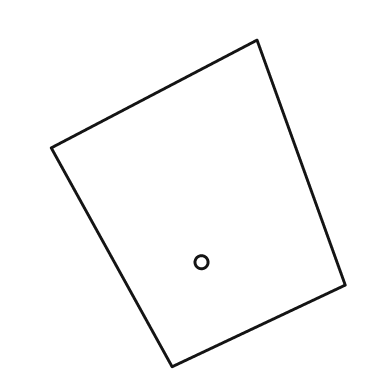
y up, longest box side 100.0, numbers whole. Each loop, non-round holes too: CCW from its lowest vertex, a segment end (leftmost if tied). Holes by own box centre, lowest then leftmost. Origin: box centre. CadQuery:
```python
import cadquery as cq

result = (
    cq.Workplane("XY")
    .moveTo(-8.0, -50.0)
    .lineTo(45.0, -25.0)
    .lineTo(18.0, 50.0)
    .lineTo(-45.0, 17.0)
    .close()
    .moveTo(1.0, -18.0)
    .circle(2.0)
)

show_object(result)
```